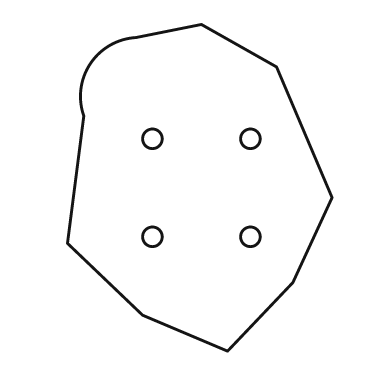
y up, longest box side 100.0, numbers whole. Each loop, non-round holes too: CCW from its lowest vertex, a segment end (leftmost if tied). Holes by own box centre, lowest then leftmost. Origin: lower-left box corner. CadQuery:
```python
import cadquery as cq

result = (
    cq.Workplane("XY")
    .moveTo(49.0, 0.0)
    .lineTo(69.0, 21.0)
    .lineTo(81.0, 47.0)
    .lineTo(64.0, 87.0)
    .lineTo(41.0, 100.0)
    .lineTo(21.0, 96.0)
    .threePointArc((7.0, 88.0), (5.0, 72.0))
    .lineTo(0.0, 33.0)
    .lineTo(23.0, 11.0)
    .close()
    .moveTo(26.0, 35.0)
    .circle(3.0)
    .moveTo(56.0, 35.0)
    .circle(3.0)
    .moveTo(26.0, 65.0)
    .circle(3.0)
    .moveTo(56.0, 65.0)
    .circle(3.0)
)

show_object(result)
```